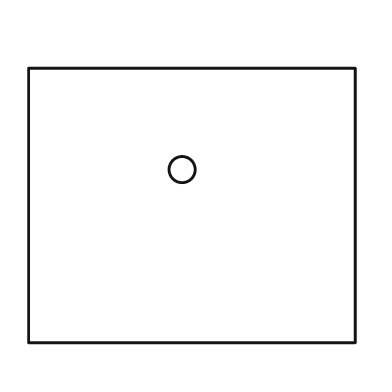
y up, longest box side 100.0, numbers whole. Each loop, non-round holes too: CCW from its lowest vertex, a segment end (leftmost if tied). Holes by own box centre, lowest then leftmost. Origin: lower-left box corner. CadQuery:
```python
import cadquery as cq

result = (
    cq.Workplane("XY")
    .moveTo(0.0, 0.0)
    .lineTo(100.0, 0.0)
    .lineTo(100.0, 84.0)
    .lineTo(0.0, 84.0)
    .close()
    .moveTo(47.0, 53.0)
    .circle(4.0)
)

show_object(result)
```